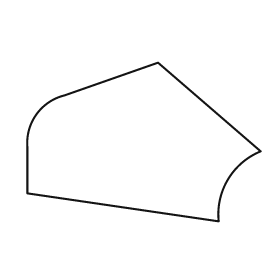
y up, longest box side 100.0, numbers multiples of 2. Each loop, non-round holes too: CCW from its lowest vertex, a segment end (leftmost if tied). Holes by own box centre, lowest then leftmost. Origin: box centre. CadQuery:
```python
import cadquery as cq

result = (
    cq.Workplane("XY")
    .moveTo(32.0, -34.0)
    .threePointArc((36.0, -16.0), (50.0, -4.0))
    .lineTo(6.0, 34.0)
    .lineTo(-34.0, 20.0)
    .threePointArc((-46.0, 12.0), (-50.0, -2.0))
    .lineTo(-50.0, -22.0)
    .close()
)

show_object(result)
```